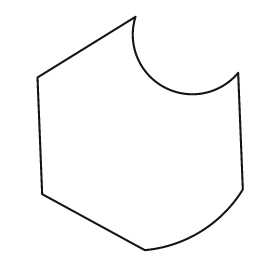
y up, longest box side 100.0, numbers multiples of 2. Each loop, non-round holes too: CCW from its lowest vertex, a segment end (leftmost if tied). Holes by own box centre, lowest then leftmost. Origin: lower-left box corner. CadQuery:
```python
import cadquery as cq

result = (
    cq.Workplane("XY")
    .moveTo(46.0, 0.0)
    .threePointArc((70.0, 8.0), (88.0, 26.0))
    .lineTo(86.0, 76.0)
    .threePointArc((54.0, 70.0), (42.0, 100.0))
    .lineTo(0.0, 74.0)
    .lineTo(2.0, 24.0)
    .close()
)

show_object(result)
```